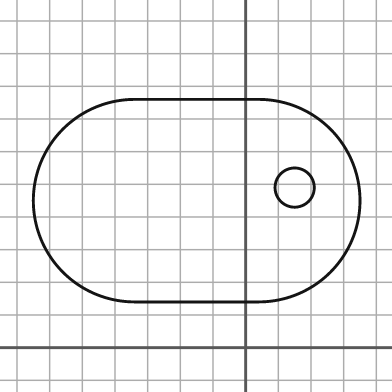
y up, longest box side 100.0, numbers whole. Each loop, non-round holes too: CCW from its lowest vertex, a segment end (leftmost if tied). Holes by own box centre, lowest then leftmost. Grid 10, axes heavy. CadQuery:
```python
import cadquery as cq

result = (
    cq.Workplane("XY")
    .moveTo(-34.0, 14.0)
    .lineTo(4.0, 14.0)
    .threePointArc((35.0, 45.0), (4.0, 76.0))
    .lineTo(-34.0, 76.0)
    .threePointArc((-65.0, 45.0), (-34.0, 14.0))
    .close()
    .moveTo(15.0, 49.0)
    .circle(6.0)
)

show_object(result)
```